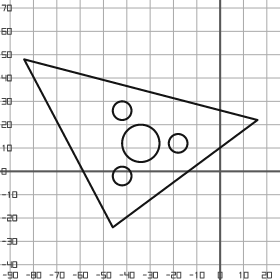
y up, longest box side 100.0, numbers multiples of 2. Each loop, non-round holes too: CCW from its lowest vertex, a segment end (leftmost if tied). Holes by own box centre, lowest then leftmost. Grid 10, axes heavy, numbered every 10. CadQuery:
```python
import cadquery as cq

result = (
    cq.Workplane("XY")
    .moveTo(-46.0, -24.0)
    .lineTo(16.0, 22.0)
    .lineTo(-84.0, 48.0)
    .close()
    .moveTo(-42.0, -2.0)
    .circle(4.0)
    .moveTo(-34.0, 12.0)
    .circle(8.0)
    .moveTo(-18.0, 12.0)
    .circle(4.0)
    .moveTo(-42.0, 26.0)
    .circle(4.0)
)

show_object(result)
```